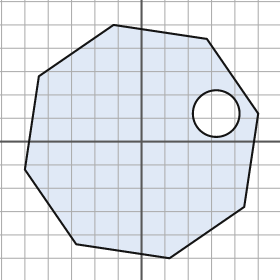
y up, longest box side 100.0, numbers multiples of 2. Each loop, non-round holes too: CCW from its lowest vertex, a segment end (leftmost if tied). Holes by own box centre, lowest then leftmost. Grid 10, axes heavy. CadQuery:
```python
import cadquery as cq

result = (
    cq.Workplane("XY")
    .moveTo(12.0, -50.0)
    .lineTo(44.0, -28.0)
    .lineTo(50.0, 12.0)
    .lineTo(28.0, 44.0)
    .lineTo(-12.0, 50.0)
    .lineTo(-44.0, 28.0)
    .lineTo(-50.0, -12.0)
    .lineTo(-28.0, -44.0)
    .close()
    .moveTo(32.0, 12.0)
    .circle(10.0)
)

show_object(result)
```